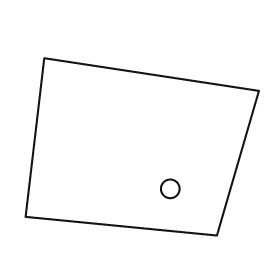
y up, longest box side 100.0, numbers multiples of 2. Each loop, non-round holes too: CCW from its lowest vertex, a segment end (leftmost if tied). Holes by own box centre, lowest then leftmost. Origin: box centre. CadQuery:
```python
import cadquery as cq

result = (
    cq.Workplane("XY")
    .moveTo(32.0, -38.0)
    .lineTo(50.0, 24.0)
    .lineTo(-42.0, 38.0)
    .lineTo(-50.0, -30.0)
    .close()
    .moveTo(12.0, -18.0)
    .circle(4.0)
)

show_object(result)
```